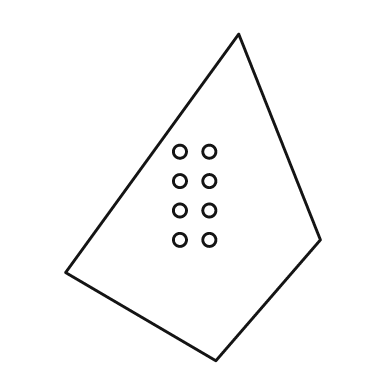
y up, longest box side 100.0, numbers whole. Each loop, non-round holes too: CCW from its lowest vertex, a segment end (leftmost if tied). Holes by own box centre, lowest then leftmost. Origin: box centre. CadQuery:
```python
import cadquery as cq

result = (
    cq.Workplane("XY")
    .moveTo(7.0, -50.0)
    .lineTo(39.0, -13.0)
    .lineTo(14.0, 50.0)
    .lineTo(-39.0, -23.0)
    .close()
    .moveTo(-4.0, -13.0)
    .circle(2.0)
    .moveTo(5.0, -13.0)
    .circle(2.0)
    .moveTo(-4.0, -4.0)
    .circle(2.0)
    .moveTo(5.0, -4.0)
    .circle(2.0)
    .moveTo(-4.0, 5.0)
    .circle(2.0)
    .moveTo(5.0, 5.0)
    .circle(2.0)
    .moveTo(-4.0, 14.0)
    .circle(2.0)
    .moveTo(5.0, 14.0)
    .circle(2.0)
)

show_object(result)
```